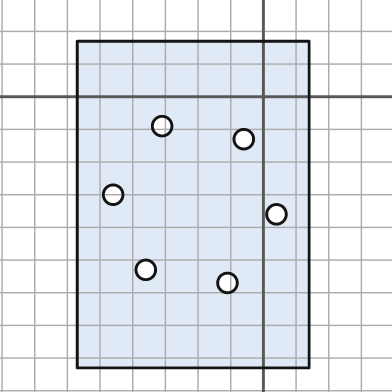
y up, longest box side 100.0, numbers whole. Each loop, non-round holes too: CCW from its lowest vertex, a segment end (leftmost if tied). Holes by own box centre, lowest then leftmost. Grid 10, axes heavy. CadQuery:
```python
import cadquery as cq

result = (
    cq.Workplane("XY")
    .moveTo(-57.0, -83.0)
    .lineTo(14.0, -83.0)
    .lineTo(14.0, 17.0)
    .lineTo(-57.0, 17.0)
    .close()
    .moveTo(-11.0, -57.0)
    .circle(3.0)
    .moveTo(-36.0, -53.0)
    .circle(3.0)
    .moveTo(4.0, -36.0)
    .circle(3.0)
    .moveTo(-46.0, -30.0)
    .circle(3.0)
    .moveTo(-6.0, -13.0)
    .circle(3.0)
    .moveTo(-31.0, -9.0)
    .circle(3.0)
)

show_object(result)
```